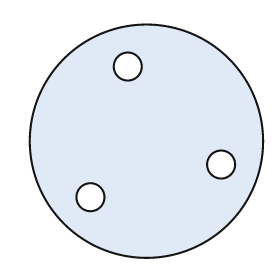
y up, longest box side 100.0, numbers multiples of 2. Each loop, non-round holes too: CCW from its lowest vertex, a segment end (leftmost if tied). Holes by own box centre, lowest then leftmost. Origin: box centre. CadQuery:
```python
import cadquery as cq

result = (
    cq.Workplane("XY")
    .moveTo(0.0, 0.0)
    .circle(50.0)
    .moveTo(-24.0, -24.0)
    .circle(6.0)
    .moveTo(32.0, -10.0)
    .circle(6.0)
    .moveTo(-8.0, 32.0)
    .circle(6.0)
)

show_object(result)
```